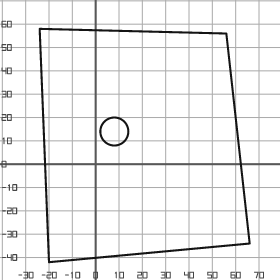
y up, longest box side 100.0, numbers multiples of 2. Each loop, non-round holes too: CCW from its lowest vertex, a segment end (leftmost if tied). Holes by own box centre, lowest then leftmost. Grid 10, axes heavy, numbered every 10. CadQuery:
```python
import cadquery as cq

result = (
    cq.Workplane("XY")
    .moveTo(-20.0, -42.0)
    .lineTo(66.0, -34.0)
    .lineTo(56.0, 56.0)
    .lineTo(-24.0, 58.0)
    .close()
    .moveTo(8.0, 14.0)
    .circle(6.0)
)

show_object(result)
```